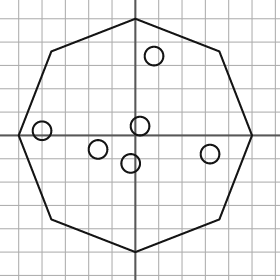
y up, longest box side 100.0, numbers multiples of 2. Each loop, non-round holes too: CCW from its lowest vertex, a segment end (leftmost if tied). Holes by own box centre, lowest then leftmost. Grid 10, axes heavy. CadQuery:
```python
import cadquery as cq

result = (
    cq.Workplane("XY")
    .moveTo(0.0, -50.0)
    .lineTo(36.0, -36.0)
    .lineTo(50.0, 0.0)
    .lineTo(36.0, 36.0)
    .lineTo(0.0, 50.0)
    .lineTo(-36.0, 36.0)
    .lineTo(-50.0, 0.0)
    .lineTo(-36.0, -36.0)
    .close()
    .moveTo(-2.0, -12.0)
    .circle(4.0)
    .moveTo(32.0, -8.0)
    .circle(4.0)
    .moveTo(-16.0, -6.0)
    .circle(4.0)
    .moveTo(-40.0, 2.0)
    .circle(4.0)
    .moveTo(2.0, 4.0)
    .circle(4.0)
    .moveTo(8.0, 34.0)
    .circle(4.0)
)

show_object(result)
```